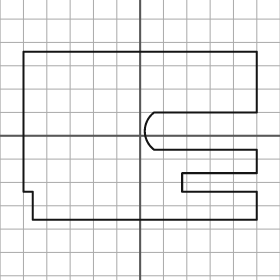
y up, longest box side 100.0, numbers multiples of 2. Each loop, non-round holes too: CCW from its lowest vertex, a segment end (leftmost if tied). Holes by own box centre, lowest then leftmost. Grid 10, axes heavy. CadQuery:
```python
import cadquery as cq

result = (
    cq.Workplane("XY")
    .moveTo(-46.0, -36.0)
    .lineTo(50.0, -36.0)
    .lineTo(50.0, -24.0)
    .lineTo(18.0, -24.0)
    .lineTo(18.0, -16.0)
    .lineTo(50.0, -16.0)
    .lineTo(50.0, -6.0)
    .lineTo(6.0, -6.0)
    .threePointArc((2.0, 2.0), (6.0, 10.0))
    .lineTo(50.0, 10.0)
    .lineTo(50.0, 36.0)
    .lineTo(-50.0, 36.0)
    .lineTo(-50.0, -24.0)
    .lineTo(-46.0, -24.0)
    .close()
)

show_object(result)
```